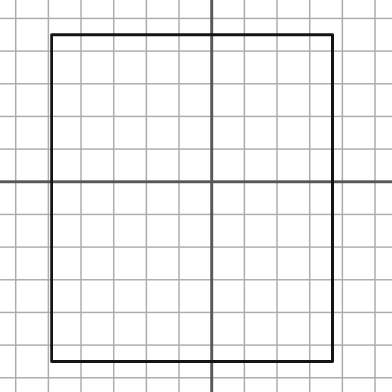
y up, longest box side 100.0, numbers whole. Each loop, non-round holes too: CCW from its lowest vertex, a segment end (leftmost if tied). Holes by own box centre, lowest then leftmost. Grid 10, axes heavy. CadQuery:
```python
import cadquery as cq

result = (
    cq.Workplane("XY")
    .moveTo(-49.0, -55.0)
    .lineTo(37.0, -55.0)
    .lineTo(37.0, 45.0)
    .lineTo(-49.0, 45.0)
    .close()
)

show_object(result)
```